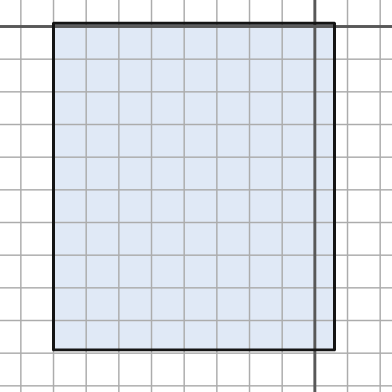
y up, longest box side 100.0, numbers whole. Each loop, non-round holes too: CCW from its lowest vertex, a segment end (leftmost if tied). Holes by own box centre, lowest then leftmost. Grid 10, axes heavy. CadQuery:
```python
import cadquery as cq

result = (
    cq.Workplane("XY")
    .moveTo(-80.0, -99.0)
    .lineTo(6.0, -99.0)
    .lineTo(6.0, 1.0)
    .lineTo(-80.0, 1.0)
    .close()
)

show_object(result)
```